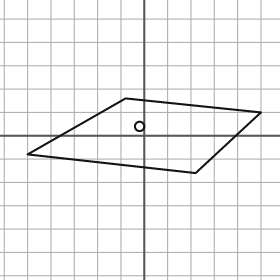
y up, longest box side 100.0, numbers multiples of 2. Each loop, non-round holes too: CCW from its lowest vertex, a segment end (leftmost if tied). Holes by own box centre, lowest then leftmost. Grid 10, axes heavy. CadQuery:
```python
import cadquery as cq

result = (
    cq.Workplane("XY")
    .moveTo(22.0, -16.0)
    .lineTo(50.0, 10.0)
    .lineTo(-8.0, 16.0)
    .lineTo(-50.0, -8.0)
    .close()
    .moveTo(-2.0, 4.0)
    .circle(2.0)
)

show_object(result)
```